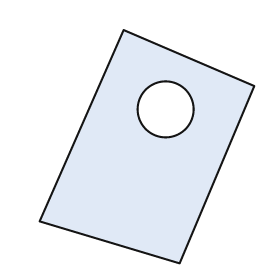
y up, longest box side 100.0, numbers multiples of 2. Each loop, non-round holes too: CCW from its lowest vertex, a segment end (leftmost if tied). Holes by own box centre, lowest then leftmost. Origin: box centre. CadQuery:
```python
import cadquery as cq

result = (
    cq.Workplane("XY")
    .moveTo(14.0, -50.0)
    .lineTo(46.0, 26.0)
    .lineTo(-10.0, 50.0)
    .lineTo(-46.0, -32.0)
    .close()
    .moveTo(8.0, 16.0)
    .circle(12.0)
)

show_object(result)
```